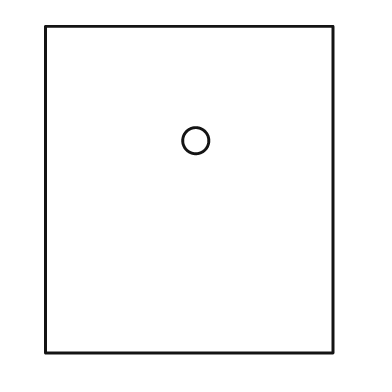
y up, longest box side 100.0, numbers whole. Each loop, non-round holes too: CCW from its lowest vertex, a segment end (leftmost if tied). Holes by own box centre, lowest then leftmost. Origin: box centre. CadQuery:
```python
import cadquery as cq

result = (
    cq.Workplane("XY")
    .moveTo(-44.0, -50.0)
    .lineTo(44.0, -50.0)
    .lineTo(44.0, 50.0)
    .lineTo(-44.0, 50.0)
    .close()
    .moveTo(2.0, 15.0)
    .circle(4.0)
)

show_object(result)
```